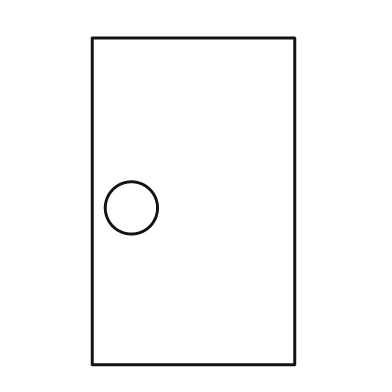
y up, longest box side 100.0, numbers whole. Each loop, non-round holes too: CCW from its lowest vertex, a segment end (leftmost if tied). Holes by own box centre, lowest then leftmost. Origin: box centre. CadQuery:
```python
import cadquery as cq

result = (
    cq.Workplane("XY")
    .moveTo(-31.0, -50.0)
    .lineTo(31.0, -50.0)
    .lineTo(31.0, 50.0)
    .lineTo(-31.0, 50.0)
    .close()
    .moveTo(-19.0, -2.0)
    .circle(8.0)
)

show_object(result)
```